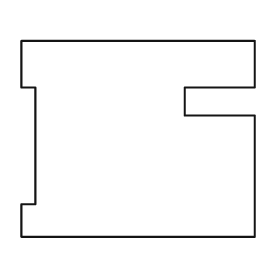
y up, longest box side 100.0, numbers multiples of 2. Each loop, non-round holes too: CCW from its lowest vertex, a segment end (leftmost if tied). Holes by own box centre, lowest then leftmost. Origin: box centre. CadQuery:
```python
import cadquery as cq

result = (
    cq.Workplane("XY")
    .moveTo(-50.0, -42.0)
    .lineTo(50.0, -42.0)
    .lineTo(50.0, 10.0)
    .lineTo(20.0, 10.0)
    .lineTo(20.0, 22.0)
    .lineTo(50.0, 22.0)
    .lineTo(50.0, 42.0)
    .lineTo(-50.0, 42.0)
    .lineTo(-50.0, 22.0)
    .lineTo(-44.0, 22.0)
    .lineTo(-44.0, -28.0)
    .lineTo(-50.0, -28.0)
    .close()
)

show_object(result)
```